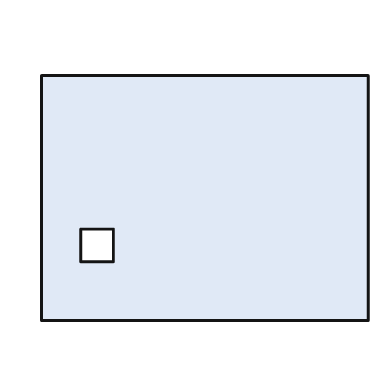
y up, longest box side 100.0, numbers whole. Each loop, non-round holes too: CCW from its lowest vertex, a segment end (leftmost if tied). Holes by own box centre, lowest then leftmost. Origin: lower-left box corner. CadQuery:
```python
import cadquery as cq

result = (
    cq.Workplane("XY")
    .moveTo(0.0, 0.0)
    .lineTo(100.0, 0.0)
    .lineTo(100.0, 75.0)
    .lineTo(0.0, 75.0)
    .close()
    .moveTo(12.0, 18.0)
    .lineTo(22.0, 18.0)
    .lineTo(22.0, 28.0)
    .lineTo(12.0, 28.0)
    .close()
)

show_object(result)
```